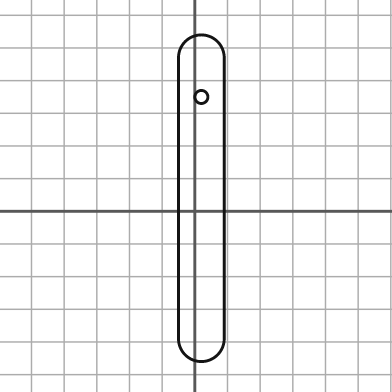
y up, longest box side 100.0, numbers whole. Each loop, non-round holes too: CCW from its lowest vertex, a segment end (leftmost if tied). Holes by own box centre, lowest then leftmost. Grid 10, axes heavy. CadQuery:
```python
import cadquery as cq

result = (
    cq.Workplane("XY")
    .moveTo(-5.0, -39.0)
    .threePointArc((2.0, -46.0), (9.0, -39.0))
    .lineTo(9.0, 47.0)
    .threePointArc((2.0, 54.0), (-5.0, 47.0))
    .close()
    .moveTo(2.0, 35.0)
    .circle(2.0)
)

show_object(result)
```